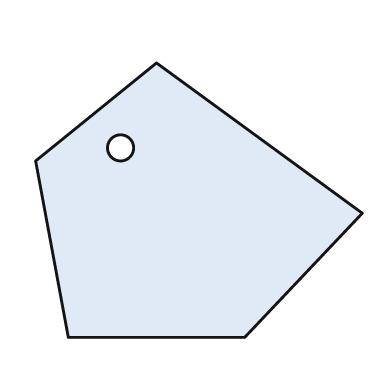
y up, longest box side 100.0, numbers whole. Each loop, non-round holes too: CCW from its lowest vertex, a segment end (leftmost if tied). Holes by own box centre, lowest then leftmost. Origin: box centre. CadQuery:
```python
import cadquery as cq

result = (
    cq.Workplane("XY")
    .moveTo(-40.0, -42.0)
    .lineTo(14.0, -42.0)
    .lineTo(50.0, -4.0)
    .lineTo(-13.0, 42.0)
    .lineTo(-50.0, 12.0)
    .close()
    .moveTo(-24.0, 16.0)
    .circle(4.0)
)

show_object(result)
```